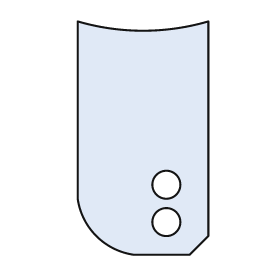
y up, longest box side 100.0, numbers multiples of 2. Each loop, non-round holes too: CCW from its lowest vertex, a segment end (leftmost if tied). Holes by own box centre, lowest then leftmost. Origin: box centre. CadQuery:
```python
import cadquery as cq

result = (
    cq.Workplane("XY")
    .moveTo(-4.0, -50.0)
    .lineTo(20.0, -50.0)
    .lineTo(28.0, -42.0)
    .lineTo(28.0, 50.0)
    .threePointArc((0.0, 46.0), (-28.0, 50.0))
    .lineTo(-28.0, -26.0)
    .threePointArc((-20.0, -42.0), (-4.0, -50.0))
    .close()
    .moveTo(10.0, -36.0)
    .circle(6.0)
    .moveTo(10.0, -20.0)
    .circle(6.0)
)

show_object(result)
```